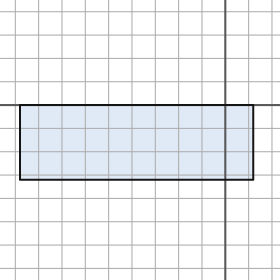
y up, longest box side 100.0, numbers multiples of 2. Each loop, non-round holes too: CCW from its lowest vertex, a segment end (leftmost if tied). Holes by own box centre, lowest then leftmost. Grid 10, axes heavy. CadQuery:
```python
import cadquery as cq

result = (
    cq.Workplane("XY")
    .moveTo(-88.0, -32.0)
    .lineTo(12.0, -32.0)
    .lineTo(12.0, 0.0)
    .lineTo(-88.0, 0.0)
    .close()
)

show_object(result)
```